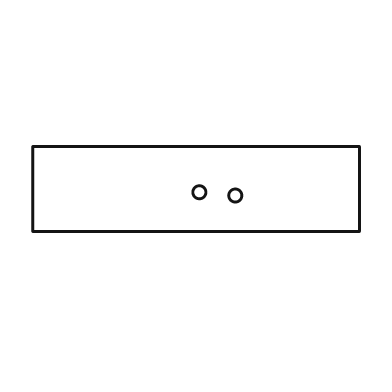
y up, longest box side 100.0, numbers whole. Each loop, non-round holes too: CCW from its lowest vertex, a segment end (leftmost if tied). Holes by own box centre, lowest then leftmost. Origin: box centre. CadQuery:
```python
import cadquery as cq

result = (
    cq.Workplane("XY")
    .moveTo(-50.0, -13.0)
    .lineTo(50.0, -13.0)
    .lineTo(50.0, 13.0)
    .lineTo(-50.0, 13.0)
    .close()
    .moveTo(12.0, -2.0)
    .circle(2.0)
    .moveTo(1.0, -1.0)
    .circle(2.0)
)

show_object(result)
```